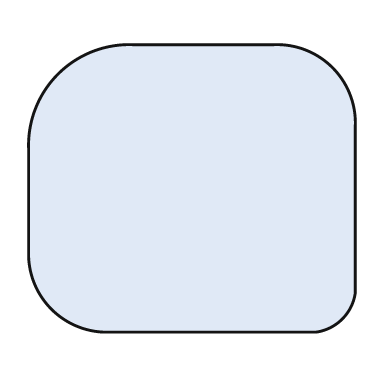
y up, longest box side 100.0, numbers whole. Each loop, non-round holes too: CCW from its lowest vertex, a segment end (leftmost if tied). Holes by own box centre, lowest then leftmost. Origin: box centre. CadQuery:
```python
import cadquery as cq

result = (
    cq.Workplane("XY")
    .moveTo(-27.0, -44.0)
    .lineTo(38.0, -44.0)
    .threePointArc((46.0, -40.0), (50.0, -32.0))
    .lineTo(50.0, 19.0)
    .threePointArc((43.0, 37.0), (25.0, 44.0))
    .lineTo(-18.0, 44.0)
    .threePointArc((-41.0, 35.0), (-50.0, 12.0))
    .lineTo(-50.0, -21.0)
    .threePointArc((-43.0, -37.0), (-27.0, -44.0))
    .close()
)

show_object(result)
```